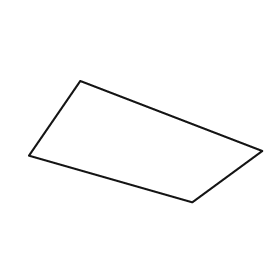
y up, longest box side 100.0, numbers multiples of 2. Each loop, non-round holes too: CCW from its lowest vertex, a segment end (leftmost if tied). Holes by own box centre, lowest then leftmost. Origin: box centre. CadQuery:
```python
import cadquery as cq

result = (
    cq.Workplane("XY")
    .moveTo(20.0, -26.0)
    .lineTo(50.0, -4.0)
    .lineTo(-28.0, 26.0)
    .lineTo(-50.0, -6.0)
    .close()
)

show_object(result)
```